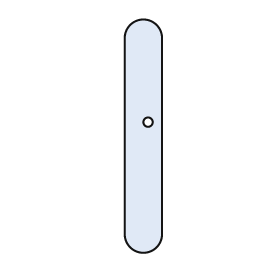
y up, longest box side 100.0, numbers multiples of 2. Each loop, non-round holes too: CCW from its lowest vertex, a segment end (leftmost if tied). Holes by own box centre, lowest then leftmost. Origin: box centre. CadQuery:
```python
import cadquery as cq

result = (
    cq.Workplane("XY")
    .moveTo(-8.0, -42.0)
    .threePointArc((0.0, -50.0), (8.0, -42.0))
    .lineTo(8.0, 42.0)
    .threePointArc((0.0, 50.0), (-8.0, 42.0))
    .close()
    .moveTo(2.0, 6.0)
    .circle(2.0)
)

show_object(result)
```